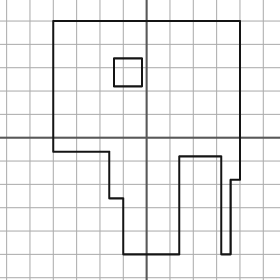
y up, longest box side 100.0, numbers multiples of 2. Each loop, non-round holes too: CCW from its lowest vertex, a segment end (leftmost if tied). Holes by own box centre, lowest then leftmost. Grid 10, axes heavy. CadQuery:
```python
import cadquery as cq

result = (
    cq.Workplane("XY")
    .moveTo(-10.0, -50.0)
    .lineTo(14.0, -50.0)
    .lineTo(14.0, -8.0)
    .lineTo(32.0, -8.0)
    .lineTo(32.0, -50.0)
    .lineTo(36.0, -50.0)
    .lineTo(36.0, -18.0)
    .lineTo(40.0, -18.0)
    .lineTo(40.0, 50.0)
    .lineTo(-40.0, 50.0)
    .lineTo(-40.0, -6.0)
    .lineTo(-16.0, -6.0)
    .lineTo(-16.0, -26.0)
    .lineTo(-10.0, -26.0)
    .close()
    .moveTo(-14.0, 22.0)
    .lineTo(-2.0, 22.0)
    .lineTo(-2.0, 34.0)
    .lineTo(-14.0, 34.0)
    .close()
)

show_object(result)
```